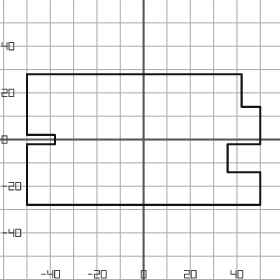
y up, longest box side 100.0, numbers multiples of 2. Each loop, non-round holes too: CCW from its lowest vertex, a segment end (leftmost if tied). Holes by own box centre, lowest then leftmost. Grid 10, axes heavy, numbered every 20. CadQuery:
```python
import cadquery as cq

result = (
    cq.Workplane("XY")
    .moveTo(-50.0, -28.0)
    .lineTo(50.0, -28.0)
    .lineTo(50.0, -14.0)
    .lineTo(36.0, -14.0)
    .lineTo(36.0, -2.0)
    .lineTo(50.0, -2.0)
    .lineTo(50.0, 14.0)
    .lineTo(42.0, 14.0)
    .lineTo(42.0, 28.0)
    .lineTo(-50.0, 28.0)
    .lineTo(-50.0, 2.0)
    .lineTo(-38.0, 2.0)
    .lineTo(-38.0, -2.0)
    .lineTo(-50.0, -2.0)
    .close()
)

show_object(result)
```